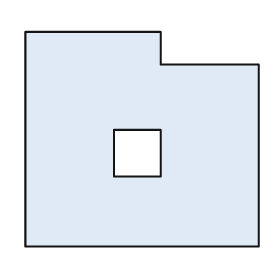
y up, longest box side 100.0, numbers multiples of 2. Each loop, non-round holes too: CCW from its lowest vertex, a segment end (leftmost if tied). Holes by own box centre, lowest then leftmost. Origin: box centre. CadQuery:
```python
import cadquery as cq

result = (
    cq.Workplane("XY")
    .moveTo(-50.0, -46.0)
    .lineTo(50.0, -46.0)
    .lineTo(50.0, 32.0)
    .lineTo(8.0, 32.0)
    .lineTo(8.0, 46.0)
    .lineTo(-50.0, 46.0)
    .close()
    .moveTo(-12.0, -16.0)
    .lineTo(8.0, -16.0)
    .lineTo(8.0, 4.0)
    .lineTo(-12.0, 4.0)
    .close()
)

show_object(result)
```